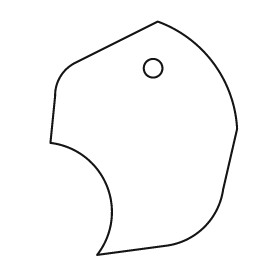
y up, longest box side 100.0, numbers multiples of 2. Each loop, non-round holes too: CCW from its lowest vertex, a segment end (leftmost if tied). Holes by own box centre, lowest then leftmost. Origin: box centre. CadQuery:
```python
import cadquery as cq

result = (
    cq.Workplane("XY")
    .moveTo(-20.0, -50.0)
    .lineTo(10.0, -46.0)
    .threePointArc((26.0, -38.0), (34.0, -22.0))
    .lineTo(40.0, 4.0)
    .threePointArc((30.0, 32.0), (6.0, 50.0))
    .lineTo(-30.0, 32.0)
    .threePointArc((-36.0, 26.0), (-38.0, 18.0))
    .lineTo(-40.0, -2.0)
    .threePointArc((-16.0, -20.0), (-20.0, -50.0))
    .close()
    .moveTo(4.0, 30.0)
    .circle(4.0)
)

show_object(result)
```